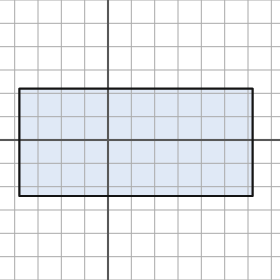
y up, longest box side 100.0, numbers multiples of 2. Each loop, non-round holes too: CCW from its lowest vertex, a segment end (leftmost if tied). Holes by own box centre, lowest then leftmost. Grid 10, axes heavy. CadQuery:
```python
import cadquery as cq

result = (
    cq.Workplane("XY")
    .moveTo(-38.0, -24.0)
    .lineTo(62.0, -24.0)
    .lineTo(62.0, 22.0)
    .lineTo(-38.0, 22.0)
    .close()
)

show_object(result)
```